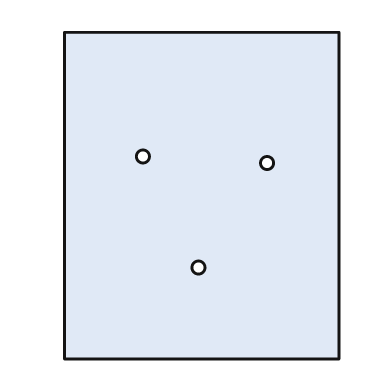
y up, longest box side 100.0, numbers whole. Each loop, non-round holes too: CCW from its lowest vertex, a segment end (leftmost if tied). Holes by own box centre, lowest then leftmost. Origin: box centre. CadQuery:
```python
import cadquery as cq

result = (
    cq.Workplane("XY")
    .moveTo(-42.0, -50.0)
    .lineTo(42.0, -50.0)
    .lineTo(42.0, 50.0)
    .lineTo(-42.0, 50.0)
    .close()
    .moveTo(-1.0, -22.0)
    .circle(2.0)
    .moveTo(20.0, 10.0)
    .circle(2.0)
    .moveTo(-18.0, 12.0)
    .circle(2.0)
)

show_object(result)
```